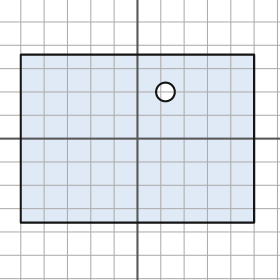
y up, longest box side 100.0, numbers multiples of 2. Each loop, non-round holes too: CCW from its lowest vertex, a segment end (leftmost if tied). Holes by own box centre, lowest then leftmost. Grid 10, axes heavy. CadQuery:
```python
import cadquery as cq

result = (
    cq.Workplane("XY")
    .moveTo(-50.0, -36.0)
    .lineTo(50.0, -36.0)
    .lineTo(50.0, 36.0)
    .lineTo(-50.0, 36.0)
    .close()
    .moveTo(12.0, 20.0)
    .circle(4.0)
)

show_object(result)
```